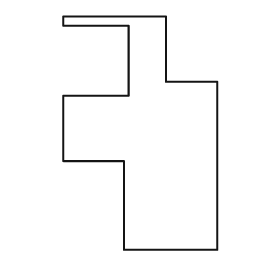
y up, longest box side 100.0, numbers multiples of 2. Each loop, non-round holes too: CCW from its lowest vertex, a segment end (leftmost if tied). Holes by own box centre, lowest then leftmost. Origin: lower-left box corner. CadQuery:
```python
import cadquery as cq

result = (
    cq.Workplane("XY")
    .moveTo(26.0, 0.0)
    .lineTo(66.0, 0.0)
    .lineTo(66.0, 72.0)
    .lineTo(44.0, 72.0)
    .lineTo(44.0, 100.0)
    .lineTo(0.0, 100.0)
    .lineTo(0.0, 96.0)
    .lineTo(28.0, 96.0)
    .lineTo(28.0, 66.0)
    .lineTo(0.0, 66.0)
    .lineTo(0.0, 38.0)
    .lineTo(26.0, 38.0)
    .close()
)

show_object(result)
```